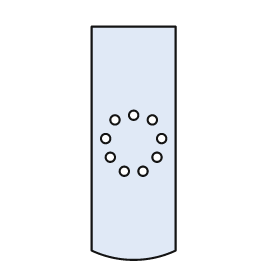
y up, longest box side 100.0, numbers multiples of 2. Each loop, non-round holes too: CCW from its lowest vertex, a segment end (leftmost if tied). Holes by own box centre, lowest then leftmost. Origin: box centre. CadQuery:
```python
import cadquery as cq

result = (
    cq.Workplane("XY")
    .moveTo(-18.0, -46.0)
    .threePointArc((0.0, -50.0), (18.0, -46.0))
    .lineTo(18.0, 50.0)
    .lineTo(-18.0, 50.0)
    .close()
    .moveTo(-4.0, -12.0)
    .circle(2.0)
    .moveTo(4.0, -12.0)
    .circle(2.0)
    .moveTo(-10.0, -6.0)
    .circle(2.0)
    .moveTo(10.0, -6.0)
    .circle(2.0)
    .moveTo(-12.0, 2.0)
    .circle(2.0)
    .moveTo(12.0, 2.0)
    .circle(2.0)
    .moveTo(-8.0, 10.0)
    .circle(2.0)
    .moveTo(8.0, 10.0)
    .circle(2.0)
    .moveTo(0.0, 12.0)
    .circle(2.0)
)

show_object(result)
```